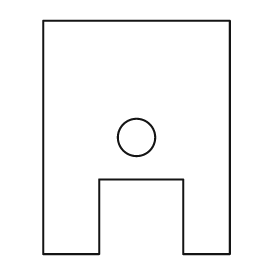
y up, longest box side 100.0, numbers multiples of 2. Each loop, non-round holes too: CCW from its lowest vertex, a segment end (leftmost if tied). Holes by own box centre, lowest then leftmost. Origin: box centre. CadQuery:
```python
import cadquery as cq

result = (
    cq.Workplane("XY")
    .moveTo(-40.0, -50.0)
    .lineTo(-16.0, -50.0)
    .lineTo(-16.0, -18.0)
    .lineTo(20.0, -18.0)
    .lineTo(20.0, -50.0)
    .lineTo(40.0, -50.0)
    .lineTo(40.0, 50.0)
    .lineTo(-40.0, 50.0)
    .close()
    .moveTo(0.0, 0.0)
    .circle(8.0)
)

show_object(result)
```